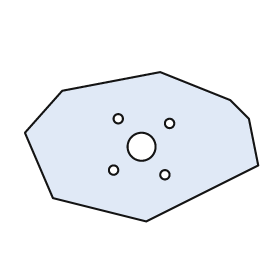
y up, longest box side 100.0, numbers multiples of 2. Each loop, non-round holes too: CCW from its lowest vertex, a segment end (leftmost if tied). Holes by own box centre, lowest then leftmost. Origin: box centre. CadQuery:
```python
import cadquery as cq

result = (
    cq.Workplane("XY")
    .moveTo(2.0, -32.0)
    .lineTo(50.0, -8.0)
    .lineTo(46.0, 12.0)
    .lineTo(38.0, 20.0)
    .lineTo(8.0, 32.0)
    .lineTo(-34.0, 24.0)
    .lineTo(-50.0, 6.0)
    .lineTo(-38.0, -22.0)
    .close()
    .moveTo(10.0, -12.0)
    .circle(2.0)
    .moveTo(-12.0, -10.0)
    .circle(2.0)
    .moveTo(0.0, 0.0)
    .circle(6.0)
    .moveTo(12.0, 10.0)
    .circle(2.0)
    .moveTo(-10.0, 12.0)
    .circle(2.0)
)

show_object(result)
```